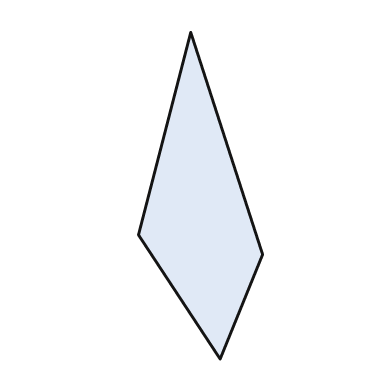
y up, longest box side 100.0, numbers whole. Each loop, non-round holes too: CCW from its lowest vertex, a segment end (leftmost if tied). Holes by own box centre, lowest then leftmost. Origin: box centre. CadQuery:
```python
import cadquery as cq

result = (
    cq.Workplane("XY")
    .moveTo(6.0, -50.0)
    .lineTo(19.0, -18.0)
    .lineTo(-3.0, 50.0)
    .lineTo(-19.0, -12.0)
    .close()
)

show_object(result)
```